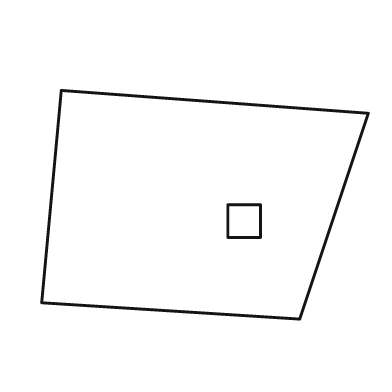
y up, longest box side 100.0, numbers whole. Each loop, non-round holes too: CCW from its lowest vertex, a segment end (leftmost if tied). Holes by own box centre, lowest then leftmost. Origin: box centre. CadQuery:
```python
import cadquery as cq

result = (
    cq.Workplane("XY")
    .moveTo(29.0, -35.0)
    .lineTo(50.0, 28.0)
    .lineTo(-44.0, 35.0)
    .lineTo(-50.0, -30.0)
    .close()
    .moveTo(7.0, -10.0)
    .lineTo(17.0, -10.0)
    .lineTo(17.0, 0.0)
    .lineTo(7.0, 0.0)
    .close()
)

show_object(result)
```